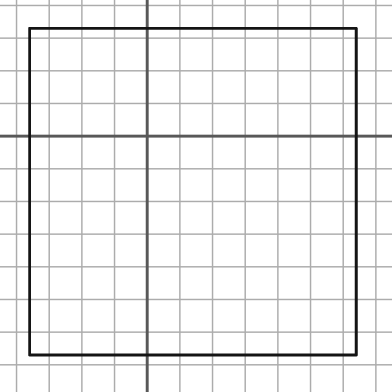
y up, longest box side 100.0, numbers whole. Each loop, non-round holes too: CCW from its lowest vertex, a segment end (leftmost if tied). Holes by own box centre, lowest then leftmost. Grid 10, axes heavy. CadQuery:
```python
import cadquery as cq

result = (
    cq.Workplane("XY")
    .moveTo(-36.0, -67.0)
    .lineTo(64.0, -67.0)
    .lineTo(64.0, 33.0)
    .lineTo(-36.0, 33.0)
    .close()
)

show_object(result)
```